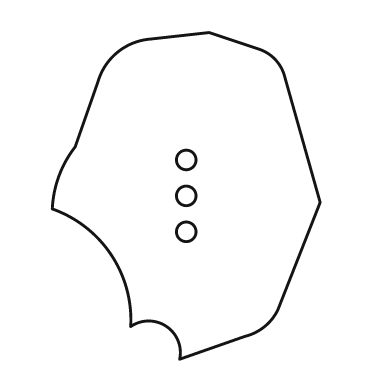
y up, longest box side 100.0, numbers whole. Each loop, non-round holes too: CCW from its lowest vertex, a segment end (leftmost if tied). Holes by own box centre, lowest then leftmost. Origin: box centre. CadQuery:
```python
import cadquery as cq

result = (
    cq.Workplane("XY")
    .moveTo(-2.0, -50.0)
    .lineTo(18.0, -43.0)
    .threePointArc((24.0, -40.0), (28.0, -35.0))
    .lineTo(41.0, -2.0)
    .lineTo(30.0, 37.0)
    .threePointArc((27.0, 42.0), (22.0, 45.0))
    .lineTo(7.0, 50.0)
    .lineTo(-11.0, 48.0)
    .threePointArc((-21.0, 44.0), (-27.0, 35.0))
    .lineTo(-34.0, 15.0)
    .threePointArc((-39.0, 6.0), (-41.0, -4.0))
    .threePointArc((-23.0, -18.0), (-17.0, -40.0))
    .threePointArc((-6.0, -40.0), (-2.0, -50.0))
    .close()
    .moveTo(0.0, -11.0)
    .circle(3.0)
    .moveTo(0.0, 0.0)
    .circle(3.0)
    .moveTo(0.0, 11.0)
    .circle(3.0)
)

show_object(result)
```